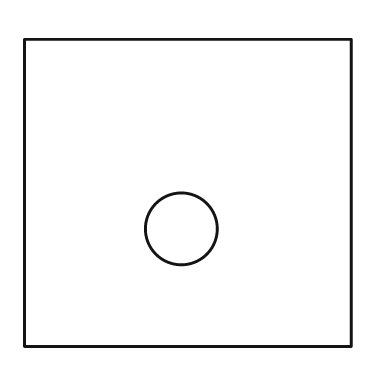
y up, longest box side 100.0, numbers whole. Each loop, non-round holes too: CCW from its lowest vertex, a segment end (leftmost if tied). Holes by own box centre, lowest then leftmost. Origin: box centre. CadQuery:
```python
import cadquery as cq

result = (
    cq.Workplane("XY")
    .moveTo(-50.0, -47.0)
    .lineTo(50.0, -47.0)
    .lineTo(50.0, 47.0)
    .lineTo(-50.0, 47.0)
    .close()
    .moveTo(-2.0, -11.0)
    .circle(11.0)
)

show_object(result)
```